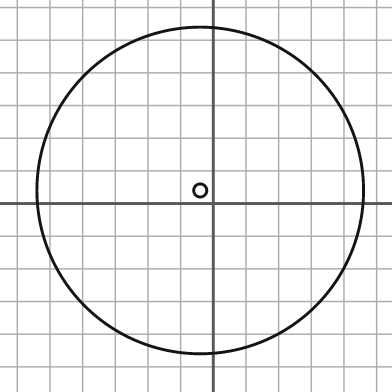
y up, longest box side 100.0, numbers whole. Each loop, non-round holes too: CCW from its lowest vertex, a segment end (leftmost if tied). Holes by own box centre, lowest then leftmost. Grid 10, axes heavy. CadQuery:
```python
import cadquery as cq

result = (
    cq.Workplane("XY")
    .moveTo(-4.0, 4.0)
    .circle(50.0)
    .moveTo(-4.0, 4.0)
    .circle(2.0)
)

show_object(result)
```